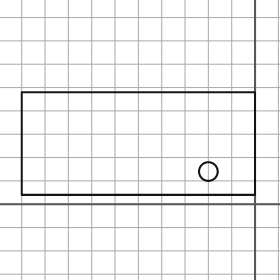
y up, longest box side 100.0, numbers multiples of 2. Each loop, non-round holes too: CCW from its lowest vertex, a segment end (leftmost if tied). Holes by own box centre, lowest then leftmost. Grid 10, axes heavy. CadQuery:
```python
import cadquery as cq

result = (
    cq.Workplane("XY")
    .moveTo(-100.0, 4.0)
    .lineTo(0.0, 4.0)
    .lineTo(0.0, 48.0)
    .lineTo(-100.0, 48.0)
    .close()
    .moveTo(-20.0, 14.0)
    .circle(4.0)
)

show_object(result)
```